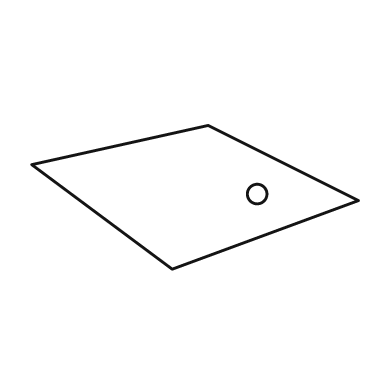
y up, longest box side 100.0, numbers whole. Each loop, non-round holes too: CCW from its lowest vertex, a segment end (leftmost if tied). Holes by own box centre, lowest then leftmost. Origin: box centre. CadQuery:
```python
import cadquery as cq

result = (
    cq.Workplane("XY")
    .moveTo(-7.0, -22.0)
    .lineTo(50.0, -1.0)
    .lineTo(4.0, 22.0)
    .lineTo(-50.0, 10.0)
    .close()
    .moveTo(19.0, 1.0)
    .circle(3.0)
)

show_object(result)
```